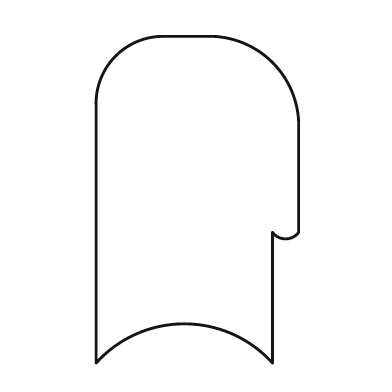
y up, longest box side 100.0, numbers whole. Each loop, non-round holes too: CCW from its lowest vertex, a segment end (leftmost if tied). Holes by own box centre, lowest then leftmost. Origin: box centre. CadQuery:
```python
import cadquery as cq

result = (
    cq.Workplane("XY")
    .moveTo(-31.0, -50.0)
    .threePointArc((-4.0, -38.0), (23.0, -50.0))
    .lineTo(23.0, -10.0)
    .threePointArc((27.0, -12.0), (31.0, -10.0))
    .lineTo(31.0, 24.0)
    .threePointArc((23.0, 42.0), (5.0, 50.0))
    .lineTo(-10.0, 50.0)
    .threePointArc((-25.0, 44.0), (-31.0, 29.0))
    .close()
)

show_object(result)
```